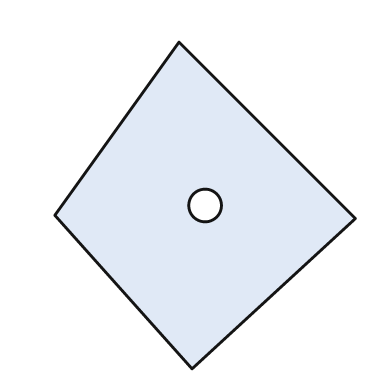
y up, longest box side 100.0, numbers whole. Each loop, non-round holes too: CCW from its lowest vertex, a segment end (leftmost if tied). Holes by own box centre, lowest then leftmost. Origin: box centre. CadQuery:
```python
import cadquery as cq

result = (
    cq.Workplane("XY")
    .moveTo(-4.0, -50.0)
    .lineTo(46.0, -4.0)
    .lineTo(-8.0, 50.0)
    .lineTo(-46.0, -3.0)
    .close()
    .moveTo(0.0, 0.0)
    .circle(5.0)
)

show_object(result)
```